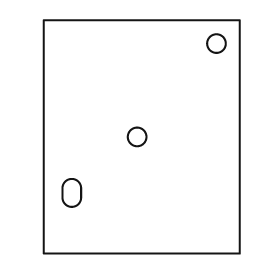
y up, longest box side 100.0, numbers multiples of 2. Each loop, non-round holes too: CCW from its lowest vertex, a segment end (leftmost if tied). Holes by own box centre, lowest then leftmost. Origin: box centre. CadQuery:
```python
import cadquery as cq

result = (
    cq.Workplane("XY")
    .moveTo(-42.0, -50.0)
    .lineTo(42.0, -50.0)
    .lineTo(42.0, 50.0)
    .lineTo(-42.0, 50.0)
    .close()
    .moveTo(-34.0, -26.0)
    .threePointArc((-30.0, -30.0), (-26.0, -26.0))
    .lineTo(-26.0, -22.0)
    .threePointArc((-30.0, -18.0), (-34.0, -22.0))
    .close()
    .moveTo(-2.0, 0.0)
    .circle(4.0)
    .moveTo(32.0, 40.0)
    .circle(4.0)
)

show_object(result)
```